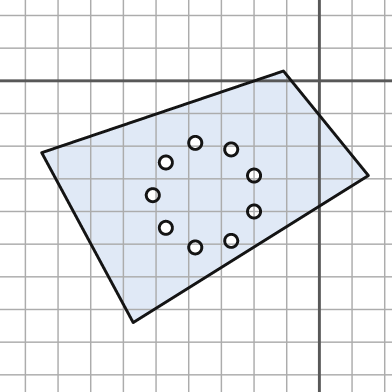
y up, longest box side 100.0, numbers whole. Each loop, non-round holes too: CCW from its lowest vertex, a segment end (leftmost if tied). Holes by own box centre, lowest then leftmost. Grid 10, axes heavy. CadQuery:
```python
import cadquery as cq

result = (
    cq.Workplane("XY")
    .moveTo(-57.0, -74.0)
    .lineTo(15.0, -29.0)
    .lineTo(-11.0, 3.0)
    .lineTo(-85.0, -22.0)
    .close()
    .moveTo(-38.0, -51.0)
    .circle(2.0)
    .moveTo(-27.0, -49.0)
    .circle(2.0)
    .moveTo(-47.0, -45.0)
    .circle(2.0)
    .moveTo(-20.0, -40.0)
    .circle(2.0)
    .moveTo(-51.0, -35.0)
    .circle(2.0)
    .moveTo(-20.0, -29.0)
    .circle(2.0)
    .moveTo(-47.0, -25.0)
    .circle(2.0)
    .moveTo(-27.0, -21.0)
    .circle(2.0)
    .moveTo(-38.0, -19.0)
    .circle(2.0)
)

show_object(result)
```